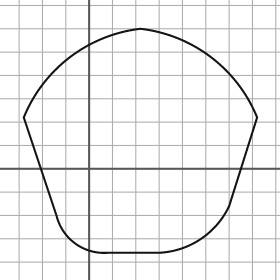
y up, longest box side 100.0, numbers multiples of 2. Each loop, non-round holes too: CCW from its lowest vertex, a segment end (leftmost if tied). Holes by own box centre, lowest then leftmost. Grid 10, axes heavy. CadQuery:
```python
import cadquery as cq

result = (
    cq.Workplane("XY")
    .moveTo(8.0, -36.0)
    .lineTo(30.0, -36.0)
    .threePointArc((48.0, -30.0), (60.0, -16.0))
    .lineTo(72.0, 22.0)
    .threePointArc((52.0, 48.0), (22.0, 60.0))
    .threePointArc((-8.0, 48.0), (-28.0, 22.0))
    .lineTo(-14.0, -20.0)
    .threePointArc((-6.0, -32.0), (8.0, -36.0))
    .close()
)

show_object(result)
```